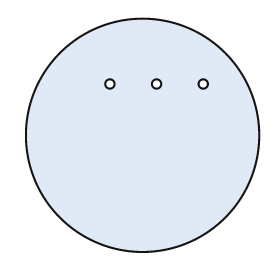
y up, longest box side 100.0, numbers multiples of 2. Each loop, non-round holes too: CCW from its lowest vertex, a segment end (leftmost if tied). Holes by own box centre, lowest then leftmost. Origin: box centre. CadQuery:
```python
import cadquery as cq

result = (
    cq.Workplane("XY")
    .moveTo(0.0, 0.0)
    .circle(50.0)
    .moveTo(-14.0, 22.0)
    .circle(2.0)
    .moveTo(6.0, 22.0)
    .circle(2.0)
    .moveTo(26.0, 22.0)
    .circle(2.0)
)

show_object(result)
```